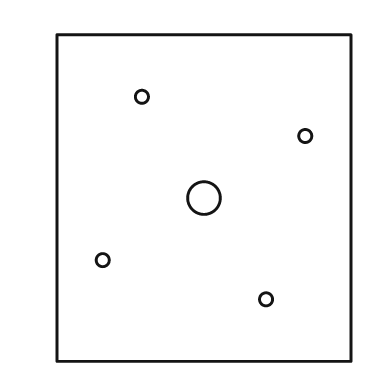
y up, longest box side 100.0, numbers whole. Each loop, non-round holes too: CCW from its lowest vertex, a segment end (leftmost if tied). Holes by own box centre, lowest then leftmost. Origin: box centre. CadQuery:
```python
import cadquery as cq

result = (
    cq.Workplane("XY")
    .moveTo(-45.0, -50.0)
    .lineTo(45.0, -50.0)
    .lineTo(45.0, 50.0)
    .lineTo(-45.0, 50.0)
    .close()
    .moveTo(19.0, -31.0)
    .circle(2.0)
    .moveTo(-31.0, -19.0)
    .circle(2.0)
    .moveTo(0.0, 0.0)
    .circle(5.0)
    .moveTo(31.0, 19.0)
    .circle(2.0)
    .moveTo(-19.0, 31.0)
    .circle(2.0)
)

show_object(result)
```